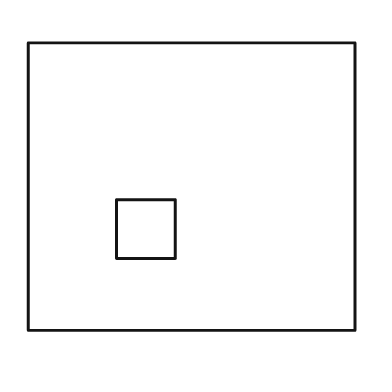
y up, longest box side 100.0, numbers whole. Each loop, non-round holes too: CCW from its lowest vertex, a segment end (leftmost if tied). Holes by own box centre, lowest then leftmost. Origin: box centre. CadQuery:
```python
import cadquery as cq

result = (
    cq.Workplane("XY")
    .moveTo(-50.0, -44.0)
    .lineTo(50.0, -44.0)
    .lineTo(50.0, 44.0)
    .lineTo(-50.0, 44.0)
    .close()
    .moveTo(-23.0, -22.0)
    .lineTo(-5.0, -22.0)
    .lineTo(-5.0, -4.0)
    .lineTo(-23.0, -4.0)
    .close()
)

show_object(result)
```